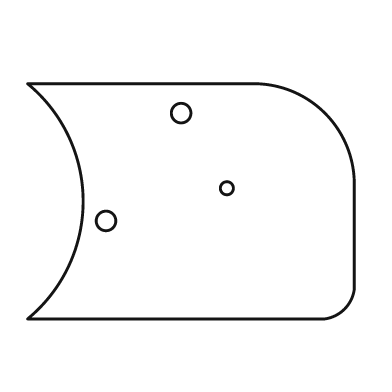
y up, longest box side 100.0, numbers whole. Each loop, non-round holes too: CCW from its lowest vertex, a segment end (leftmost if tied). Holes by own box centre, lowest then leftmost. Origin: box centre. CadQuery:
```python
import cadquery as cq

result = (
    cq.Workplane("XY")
    .moveTo(-50.0, -36.0)
    .lineTo(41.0, -36.0)
    .threePointArc((47.0, -33.0), (50.0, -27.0))
    .lineTo(50.0, 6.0)
    .threePointArc((41.0, 27.0), (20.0, 36.0))
    .lineTo(-50.0, 36.0)
    .threePointArc((-33.0, 0.0), (-50.0, -36.0))
    .close()
    .moveTo(-26.0, -6.0)
    .circle(3.0)
    .moveTo(11.0, 4.0)
    .circle(2.0)
    .moveTo(-3.0, 27.0)
    .circle(3.0)
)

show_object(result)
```